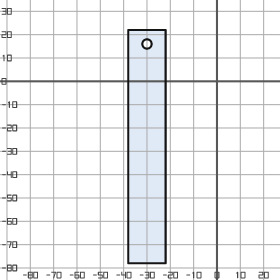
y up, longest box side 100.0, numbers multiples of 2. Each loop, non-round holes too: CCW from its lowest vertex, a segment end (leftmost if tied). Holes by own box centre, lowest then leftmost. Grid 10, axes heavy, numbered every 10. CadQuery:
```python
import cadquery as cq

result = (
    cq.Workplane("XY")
    .moveTo(-38.0, -78.0)
    .lineTo(-22.0, -78.0)
    .lineTo(-22.0, 22.0)
    .lineTo(-38.0, 22.0)
    .close()
    .moveTo(-30.0, 16.0)
    .circle(2.0)
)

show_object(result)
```